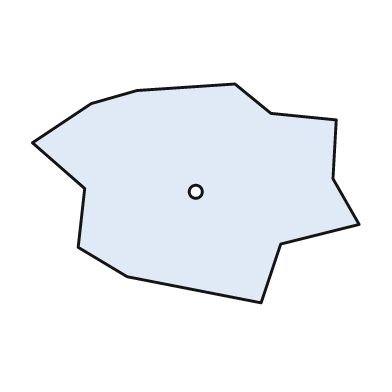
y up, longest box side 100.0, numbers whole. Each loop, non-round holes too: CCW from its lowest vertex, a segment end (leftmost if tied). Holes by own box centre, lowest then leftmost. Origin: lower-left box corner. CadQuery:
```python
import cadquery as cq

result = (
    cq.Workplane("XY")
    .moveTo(70.0, 0.0)
    .lineTo(76.0, 18.0)
    .lineTo(100.0, 24.0)
    .lineTo(92.0, 38.0)
    .lineTo(93.0, 56.0)
    .lineTo(73.0, 58.0)
    .lineTo(62.0, 67.0)
    .lineTo(32.0, 65.0)
    .lineTo(18.0, 61.0)
    .lineTo(0.0, 49.0)
    .lineTo(16.0, 35.0)
    .lineTo(14.0, 17.0)
    .lineTo(29.0, 8.0)
    .close()
    .moveTo(50.0, 34.0)
    .circle(2.0)
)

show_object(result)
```